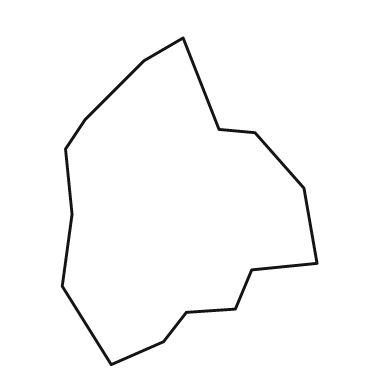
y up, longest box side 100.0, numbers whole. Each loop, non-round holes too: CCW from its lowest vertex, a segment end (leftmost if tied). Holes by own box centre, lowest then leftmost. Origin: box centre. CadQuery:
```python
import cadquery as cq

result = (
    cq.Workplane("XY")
    .moveTo(-24.0, -50.0)
    .lineTo(-8.0, -43.0)
    .lineTo(-1.0, -34.0)
    .lineTo(14.0, -33.0)
    .lineTo(19.0, -21.0)
    .lineTo(39.0, -19.0)
    .lineTo(35.0, 4.0)
    .lineTo(20.0, 21.0)
    .lineTo(9.0, 22.0)
    .lineTo(-2.0, 50.0)
    .lineTo(-14.0, 43.0)
    .lineTo(-32.0, 25.0)
    .lineTo(-38.0, 16.0)
    .lineTo(-36.0, -4.0)
    .lineTo(-39.0, -26.0)
    .close()
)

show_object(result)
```